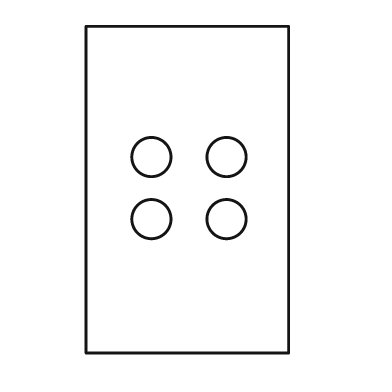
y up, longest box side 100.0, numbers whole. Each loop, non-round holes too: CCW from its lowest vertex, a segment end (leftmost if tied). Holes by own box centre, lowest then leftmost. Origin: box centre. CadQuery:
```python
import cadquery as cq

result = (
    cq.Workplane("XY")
    .moveTo(-31.0, -50.0)
    .lineTo(31.0, -50.0)
    .lineTo(31.0, 50.0)
    .lineTo(-31.0, 50.0)
    .close()
    .moveTo(-11.0, -9.0)
    .circle(6.0)
    .moveTo(12.0, -9.0)
    .circle(6.0)
    .moveTo(-11.0, 10.0)
    .circle(6.0)
    .moveTo(12.0, 10.0)
    .circle(6.0)
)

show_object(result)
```